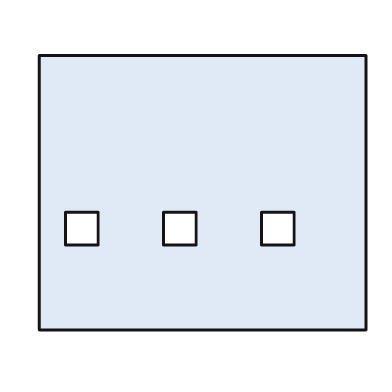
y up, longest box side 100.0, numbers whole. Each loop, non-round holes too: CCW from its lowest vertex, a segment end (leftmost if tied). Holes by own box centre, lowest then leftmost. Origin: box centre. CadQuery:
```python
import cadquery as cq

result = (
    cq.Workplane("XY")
    .moveTo(-50.0, -42.0)
    .lineTo(50.0, -42.0)
    .lineTo(50.0, 42.0)
    .lineTo(-50.0, 42.0)
    .close()
    .moveTo(-42.0, -16.0)
    .lineTo(-32.0, -16.0)
    .lineTo(-32.0, -6.0)
    .lineTo(-42.0, -6.0)
    .close()
    .moveTo(-12.0, -16.0)
    .lineTo(-2.0, -16.0)
    .lineTo(-2.0, -6.0)
    .lineTo(-12.0, -6.0)
    .close()
    .moveTo(18.0, -16.0)
    .lineTo(28.0, -16.0)
    .lineTo(28.0, -6.0)
    .lineTo(18.0, -6.0)
    .close()
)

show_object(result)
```